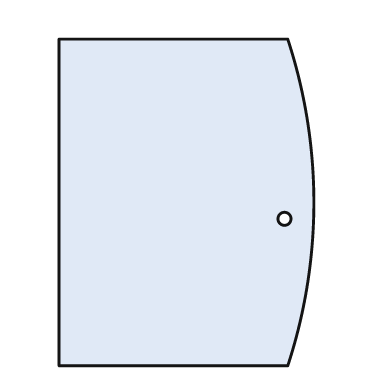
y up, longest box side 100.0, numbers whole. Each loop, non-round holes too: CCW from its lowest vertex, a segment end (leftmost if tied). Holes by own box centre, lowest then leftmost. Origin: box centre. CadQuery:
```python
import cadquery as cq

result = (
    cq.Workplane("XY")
    .moveTo(-39.0, -50.0)
    .lineTo(31.0, -50.0)
    .threePointArc((39.0, 0.0), (31.0, 50.0))
    .lineTo(-39.0, 50.0)
    .close()
    .moveTo(30.0, -5.0)
    .circle(2.0)
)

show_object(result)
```